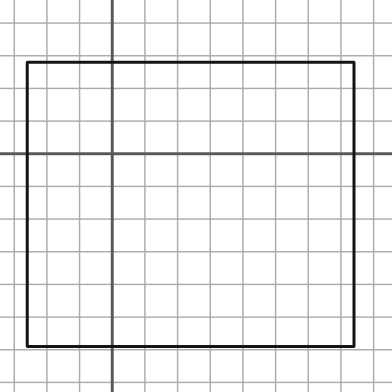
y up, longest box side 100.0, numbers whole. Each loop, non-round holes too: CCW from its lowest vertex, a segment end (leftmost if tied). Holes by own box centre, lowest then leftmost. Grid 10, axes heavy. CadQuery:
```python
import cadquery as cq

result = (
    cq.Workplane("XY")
    .moveTo(-26.0, -59.0)
    .lineTo(74.0, -59.0)
    .lineTo(74.0, 28.0)
    .lineTo(-26.0, 28.0)
    .close()
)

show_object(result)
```